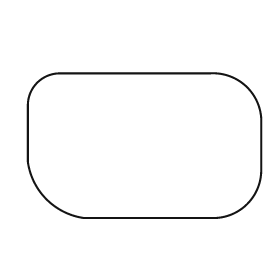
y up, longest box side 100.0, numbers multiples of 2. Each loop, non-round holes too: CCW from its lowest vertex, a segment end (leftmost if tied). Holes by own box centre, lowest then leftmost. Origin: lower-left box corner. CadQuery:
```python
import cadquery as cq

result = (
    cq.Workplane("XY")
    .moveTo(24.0, 0.0)
    .lineTo(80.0, 0.0)
    .threePointArc((94.0, 6.0), (100.0, 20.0))
    .lineTo(100.0, 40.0)
    .threePointArc((94.0, 56.0), (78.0, 62.0))
    .lineTo(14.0, 62.0)
    .threePointArc((4.0, 58.0), (0.0, 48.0))
    .lineTo(0.0, 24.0)
    .threePointArc((8.0, 8.0), (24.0, 0.0))
    .close()
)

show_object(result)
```